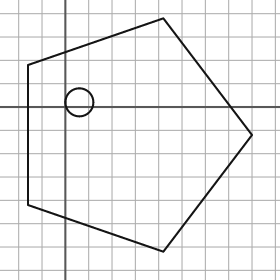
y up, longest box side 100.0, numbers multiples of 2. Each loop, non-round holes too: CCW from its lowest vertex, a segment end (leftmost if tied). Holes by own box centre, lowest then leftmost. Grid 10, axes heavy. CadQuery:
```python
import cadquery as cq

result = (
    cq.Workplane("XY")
    .moveTo(42.0, -62.0)
    .lineTo(80.0, -12.0)
    .lineTo(42.0, 38.0)
    .lineTo(-16.0, 18.0)
    .lineTo(-16.0, -42.0)
    .close()
    .moveTo(6.0, 2.0)
    .circle(6.0)
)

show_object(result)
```